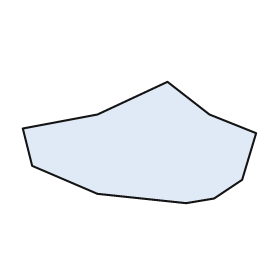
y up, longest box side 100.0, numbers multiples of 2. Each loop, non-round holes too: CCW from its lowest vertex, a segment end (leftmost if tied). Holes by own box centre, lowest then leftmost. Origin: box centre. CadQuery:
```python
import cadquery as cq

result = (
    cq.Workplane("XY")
    .moveTo(20.0, -26.0)
    .lineTo(32.0, -24.0)
    .lineTo(44.0, -16.0)
    .lineTo(50.0, 4.0)
    .lineTo(30.0, 12.0)
    .lineTo(12.0, 26.0)
    .lineTo(-18.0, 12.0)
    .lineTo(-50.0, 6.0)
    .lineTo(-46.0, -10.0)
    .lineTo(-18.0, -22.0)
    .close()
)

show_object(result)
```